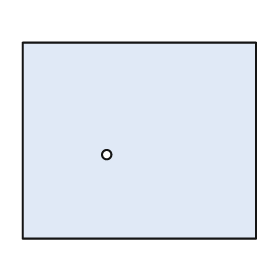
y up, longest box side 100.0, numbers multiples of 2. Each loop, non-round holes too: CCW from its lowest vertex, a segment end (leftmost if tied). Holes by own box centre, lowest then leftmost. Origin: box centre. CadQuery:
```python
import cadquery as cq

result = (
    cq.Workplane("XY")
    .moveTo(-50.0, -42.0)
    .lineTo(50.0, -42.0)
    .lineTo(50.0, 42.0)
    .lineTo(-50.0, 42.0)
    .close()
    .moveTo(-14.0, -6.0)
    .circle(2.0)
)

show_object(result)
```